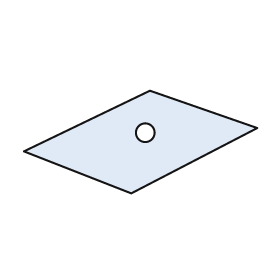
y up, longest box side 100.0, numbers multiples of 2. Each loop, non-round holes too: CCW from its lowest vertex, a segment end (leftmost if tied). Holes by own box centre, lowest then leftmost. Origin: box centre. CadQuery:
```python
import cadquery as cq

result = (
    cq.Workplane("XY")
    .moveTo(-4.0, -22.0)
    .lineTo(50.0, 6.0)
    .lineTo(4.0, 22.0)
    .lineTo(-50.0, -4.0)
    .close()
    .moveTo(2.0, 4.0)
    .circle(4.0)
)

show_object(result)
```